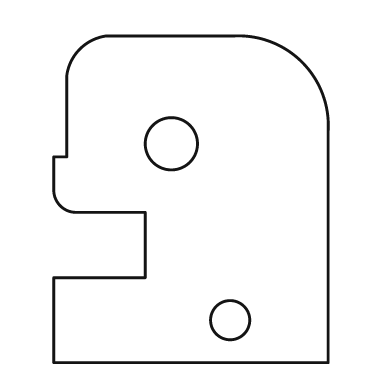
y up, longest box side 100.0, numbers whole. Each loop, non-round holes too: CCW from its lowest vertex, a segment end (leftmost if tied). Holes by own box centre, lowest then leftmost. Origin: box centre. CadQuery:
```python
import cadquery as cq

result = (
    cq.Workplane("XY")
    .moveTo(-42.0, -50.0)
    .lineTo(42.0, -50.0)
    .lineTo(42.0, 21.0)
    .threePointArc((34.0, 42.0), (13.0, 50.0))
    .lineTo(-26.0, 50.0)
    .threePointArc((-34.0, 46.0), (-38.0, 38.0))
    .lineTo(-38.0, 13.0)
    .lineTo(-42.0, 13.0)
    .lineTo(-42.0, 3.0)
    .threePointArc((-40.0, -2.0), (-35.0, -4.0))
    .lineTo(-14.0, -4.0)
    .lineTo(-14.0, -24.0)
    .lineTo(-42.0, -24.0)
    .close()
    .moveTo(12.0, -37.0)
    .circle(6.0)
    .moveTo(-6.0, 17.0)
    .circle(8.0)
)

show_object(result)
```